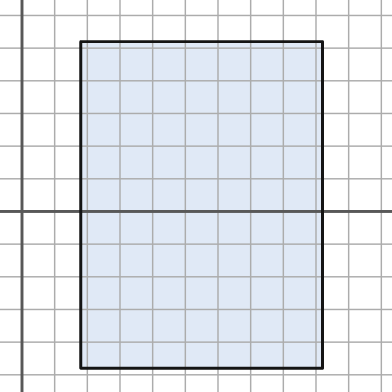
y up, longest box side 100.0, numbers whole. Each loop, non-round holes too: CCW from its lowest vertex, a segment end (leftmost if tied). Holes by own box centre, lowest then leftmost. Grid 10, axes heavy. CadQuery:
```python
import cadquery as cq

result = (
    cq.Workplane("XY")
    .moveTo(18.0, -48.0)
    .lineTo(92.0, -48.0)
    .lineTo(92.0, 52.0)
    .lineTo(18.0, 52.0)
    .close()
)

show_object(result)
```